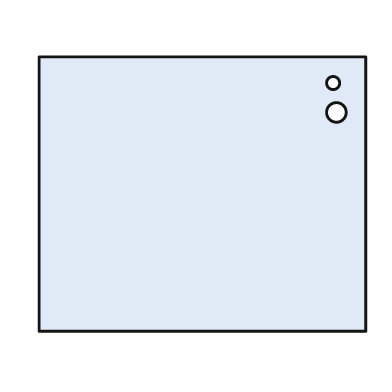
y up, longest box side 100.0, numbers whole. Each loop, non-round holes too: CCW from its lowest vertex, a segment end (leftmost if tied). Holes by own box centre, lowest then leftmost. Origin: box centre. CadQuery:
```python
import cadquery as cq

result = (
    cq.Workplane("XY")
    .moveTo(-50.0, -42.0)
    .lineTo(50.0, -42.0)
    .lineTo(50.0, 42.0)
    .lineTo(-50.0, 42.0)
    .close()
    .moveTo(41.0, 25.0)
    .circle(3.0)
    .moveTo(40.0, 34.0)
    .circle(2.0)
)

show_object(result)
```